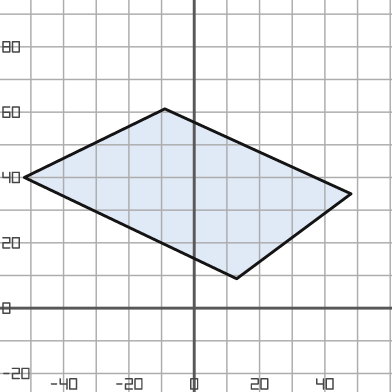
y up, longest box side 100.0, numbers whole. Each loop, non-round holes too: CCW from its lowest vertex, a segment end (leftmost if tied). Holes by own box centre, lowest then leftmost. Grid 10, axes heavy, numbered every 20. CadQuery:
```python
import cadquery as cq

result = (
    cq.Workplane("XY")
    .moveTo(13.0, 9.0)
    .lineTo(48.0, 35.0)
    .lineTo(-9.0, 61.0)
    .lineTo(-52.0, 40.0)
    .close()
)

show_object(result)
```